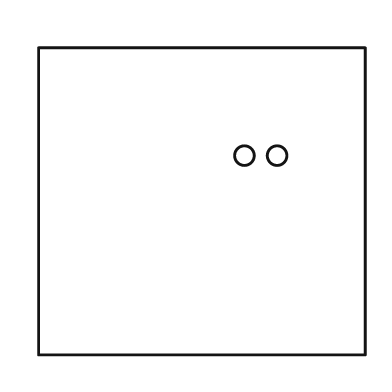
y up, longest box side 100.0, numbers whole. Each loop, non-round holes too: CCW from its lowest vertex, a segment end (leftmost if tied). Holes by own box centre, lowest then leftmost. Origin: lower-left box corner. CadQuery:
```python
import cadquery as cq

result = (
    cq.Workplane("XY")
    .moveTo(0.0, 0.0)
    .lineTo(100.0, 0.0)
    .lineTo(100.0, 94.0)
    .lineTo(0.0, 94.0)
    .close()
    .moveTo(63.0, 61.0)
    .circle(3.0)
    .moveTo(73.0, 61.0)
    .circle(3.0)
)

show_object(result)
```